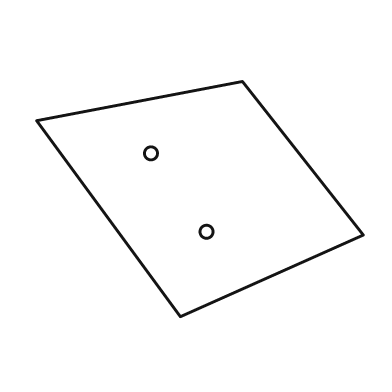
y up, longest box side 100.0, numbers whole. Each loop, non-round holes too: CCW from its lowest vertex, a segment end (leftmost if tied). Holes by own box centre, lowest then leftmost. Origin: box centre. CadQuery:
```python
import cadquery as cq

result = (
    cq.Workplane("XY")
    .moveTo(-6.0, -36.0)
    .lineTo(50.0, -11.0)
    .lineTo(13.0, 36.0)
    .lineTo(-50.0, 24.0)
    .close()
    .moveTo(2.0, -10.0)
    .circle(2.0)
    .moveTo(-15.0, 14.0)
    .circle(2.0)
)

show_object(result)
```